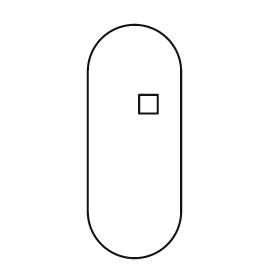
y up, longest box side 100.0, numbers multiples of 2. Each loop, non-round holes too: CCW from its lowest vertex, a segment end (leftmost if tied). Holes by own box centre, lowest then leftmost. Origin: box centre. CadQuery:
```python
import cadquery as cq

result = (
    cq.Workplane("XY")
    .moveTo(-20.0, -30.0)
    .threePointArc((0.0, -50.0), (20.0, -30.0))
    .lineTo(20.0, 30.0)
    .threePointArc((0.0, 50.0), (-20.0, 30.0))
    .close()
    .moveTo(2.0, 12.0)
    .lineTo(10.0, 12.0)
    .lineTo(10.0, 20.0)
    .lineTo(2.0, 20.0)
    .close()
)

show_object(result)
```